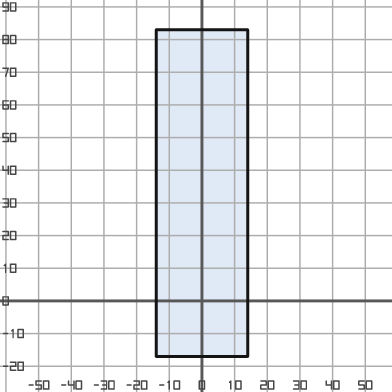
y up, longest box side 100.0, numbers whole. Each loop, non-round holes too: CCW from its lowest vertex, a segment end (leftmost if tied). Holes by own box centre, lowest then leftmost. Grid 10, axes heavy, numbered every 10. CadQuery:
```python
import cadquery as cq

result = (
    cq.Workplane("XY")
    .moveTo(-14.0, -17.0)
    .lineTo(14.0, -17.0)
    .lineTo(14.0, 83.0)
    .lineTo(-14.0, 83.0)
    .close()
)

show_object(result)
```